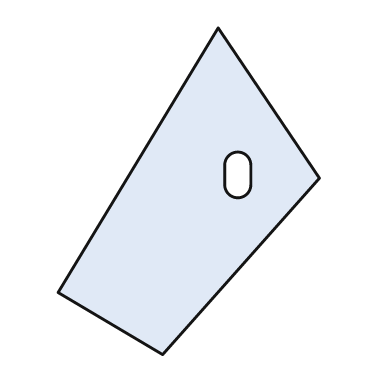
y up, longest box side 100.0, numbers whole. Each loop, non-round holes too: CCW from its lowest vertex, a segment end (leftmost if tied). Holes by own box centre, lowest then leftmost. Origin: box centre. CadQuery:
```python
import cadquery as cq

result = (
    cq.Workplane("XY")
    .moveTo(-8.0, -50.0)
    .lineTo(40.0, 4.0)
    .lineTo(9.0, 50.0)
    .lineTo(-40.0, -31.0)
    .close()
    .moveTo(11.0, 2.0)
    .threePointArc((15.0, -2.0), (19.0, 2.0))
    .lineTo(19.0, 8.0)
    .threePointArc((15.0, 12.0), (11.0, 8.0))
    .close()
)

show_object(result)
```